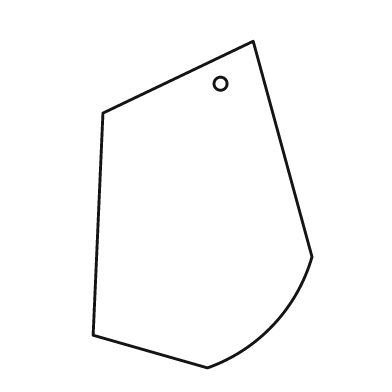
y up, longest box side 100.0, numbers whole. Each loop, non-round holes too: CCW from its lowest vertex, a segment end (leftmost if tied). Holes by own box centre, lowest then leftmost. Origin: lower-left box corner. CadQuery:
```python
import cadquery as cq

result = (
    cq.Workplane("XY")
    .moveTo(35.0, 0.0)
    .threePointArc((55.0, 13.0), (67.0, 34.0))
    .lineTo(49.0, 100.0)
    .lineTo(3.0, 78.0)
    .lineTo(0.0, 10.0)
    .close()
    .moveTo(39.0, 87.0)
    .circle(2.0)
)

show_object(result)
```